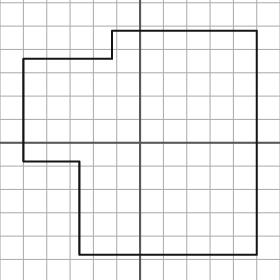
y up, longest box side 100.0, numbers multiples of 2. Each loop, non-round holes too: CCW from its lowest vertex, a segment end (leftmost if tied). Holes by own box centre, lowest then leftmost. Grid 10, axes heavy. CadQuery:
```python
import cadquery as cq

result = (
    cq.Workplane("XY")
    .moveTo(-26.0, -48.0)
    .lineTo(50.0, -48.0)
    .lineTo(50.0, 48.0)
    .lineTo(-12.0, 48.0)
    .lineTo(-12.0, 36.0)
    .lineTo(-50.0, 36.0)
    .lineTo(-50.0, -8.0)
    .lineTo(-26.0, -8.0)
    .close()
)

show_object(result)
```